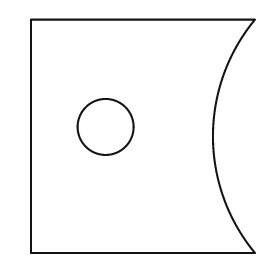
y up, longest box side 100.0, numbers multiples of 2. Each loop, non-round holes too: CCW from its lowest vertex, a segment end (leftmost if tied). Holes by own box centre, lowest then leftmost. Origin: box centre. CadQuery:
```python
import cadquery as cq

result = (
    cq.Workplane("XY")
    .moveTo(-48.0, -50.0)
    .lineTo(48.0, -50.0)
    .threePointArc((30.0, 0.0), (48.0, 50.0))
    .lineTo(-48.0, 50.0)
    .close()
    .moveTo(-16.0, 4.0)
    .circle(12.0)
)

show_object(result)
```